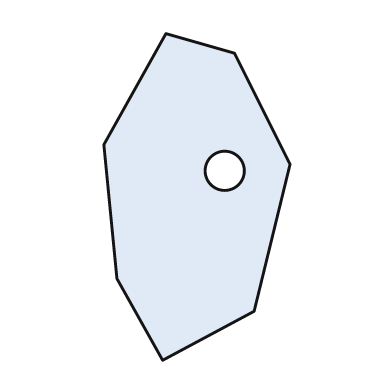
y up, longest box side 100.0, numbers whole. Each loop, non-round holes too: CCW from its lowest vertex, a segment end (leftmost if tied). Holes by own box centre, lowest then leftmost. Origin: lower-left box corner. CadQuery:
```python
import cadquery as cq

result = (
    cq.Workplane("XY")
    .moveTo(18.0, 0.0)
    .lineTo(46.0, 15.0)
    .lineTo(57.0, 60.0)
    .lineTo(40.0, 94.0)
    .lineTo(19.0, 100.0)
    .lineTo(0.0, 66.0)
    .lineTo(4.0, 25.0)
    .close()
    .moveTo(37.0, 58.0)
    .circle(6.0)
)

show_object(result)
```